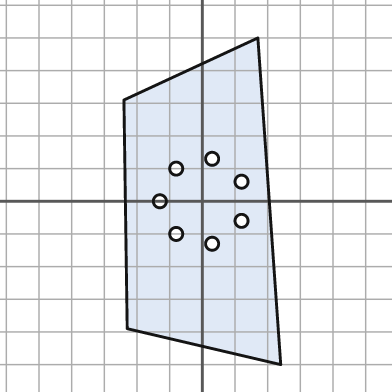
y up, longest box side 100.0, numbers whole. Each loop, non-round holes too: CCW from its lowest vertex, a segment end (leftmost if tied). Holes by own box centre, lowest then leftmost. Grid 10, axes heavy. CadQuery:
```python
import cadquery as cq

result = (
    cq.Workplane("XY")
    .moveTo(24.0, -50.0)
    .lineTo(17.0, 50.0)
    .lineTo(-24.0, 31.0)
    .lineTo(-23.0, -39.0)
    .close()
    .moveTo(3.0, -13.0)
    .circle(2.0)
    .moveTo(-8.0, -10.0)
    .circle(2.0)
    .moveTo(12.0, -6.0)
    .circle(2.0)
    .moveTo(-13.0, 0.0)
    .circle(2.0)
    .moveTo(12.0, 6.0)
    .circle(2.0)
    .moveTo(-8.0, 10.0)
    .circle(2.0)
    .moveTo(3.0, 13.0)
    .circle(2.0)
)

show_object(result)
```